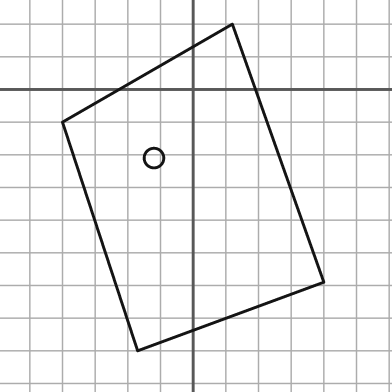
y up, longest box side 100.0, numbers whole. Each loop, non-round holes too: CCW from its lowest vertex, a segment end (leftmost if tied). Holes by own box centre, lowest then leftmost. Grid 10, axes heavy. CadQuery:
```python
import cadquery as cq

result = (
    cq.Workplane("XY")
    .moveTo(-17.0, -80.0)
    .lineTo(40.0, -59.0)
    .lineTo(12.0, 20.0)
    .lineTo(-40.0, -10.0)
    .close()
    .moveTo(-12.0, -21.0)
    .circle(3.0)
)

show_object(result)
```